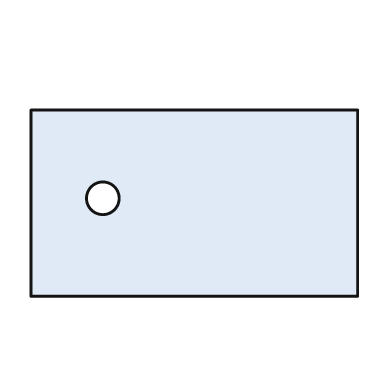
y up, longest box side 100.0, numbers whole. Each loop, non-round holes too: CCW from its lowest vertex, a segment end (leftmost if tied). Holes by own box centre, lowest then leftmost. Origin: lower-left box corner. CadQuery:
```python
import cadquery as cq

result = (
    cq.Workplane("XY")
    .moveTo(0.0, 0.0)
    .lineTo(100.0, 0.0)
    .lineTo(100.0, 57.0)
    .lineTo(0.0, 57.0)
    .close()
    .moveTo(22.0, 30.0)
    .circle(5.0)
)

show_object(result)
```